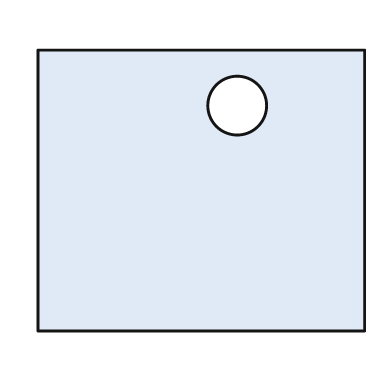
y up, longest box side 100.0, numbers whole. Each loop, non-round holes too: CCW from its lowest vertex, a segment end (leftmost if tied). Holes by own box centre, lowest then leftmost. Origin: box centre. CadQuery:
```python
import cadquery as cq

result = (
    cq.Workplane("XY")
    .moveTo(-50.0, -43.0)
    .lineTo(50.0, -43.0)
    .lineTo(50.0, 43.0)
    .lineTo(-50.0, 43.0)
    .close()
    .moveTo(11.0, 26.0)
    .circle(9.0)
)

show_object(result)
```